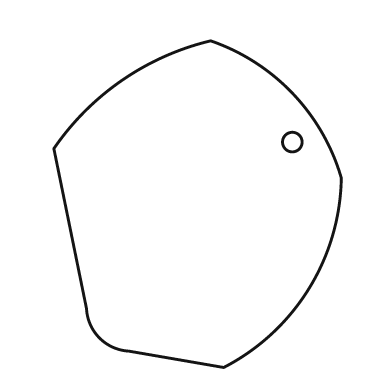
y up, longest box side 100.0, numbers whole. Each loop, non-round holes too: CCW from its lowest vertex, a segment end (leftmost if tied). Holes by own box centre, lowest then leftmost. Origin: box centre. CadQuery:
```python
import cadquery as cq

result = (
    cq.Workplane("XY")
    .moveTo(8.0, -50.0)
    .threePointArc((34.0, -26.0), (44.0, 8.0))
    .threePointArc((29.0, 34.0), (4.0, 50.0))
    .threePointArc((-23.0, 38.0), (-44.0, 17.0))
    .lineTo(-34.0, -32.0)
    .threePointArc((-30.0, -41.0), (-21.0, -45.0))
    .close()
    .moveTo(29.0, 19.0)
    .circle(3.0)
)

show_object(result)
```